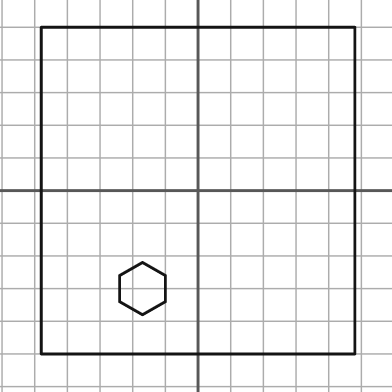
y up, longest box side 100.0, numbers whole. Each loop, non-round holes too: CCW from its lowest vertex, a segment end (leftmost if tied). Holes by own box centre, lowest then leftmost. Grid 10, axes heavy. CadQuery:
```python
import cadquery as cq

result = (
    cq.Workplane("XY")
    .moveTo(-48.0, -50.0)
    .lineTo(48.0, -50.0)
    .lineTo(48.0, 50.0)
    .lineTo(-48.0, 50.0)
    .close()
    .moveTo(-17.0, -38.0)
    .lineTo(-10.0, -34.0)
    .lineTo(-10.0, -26.0)
    .lineTo(-17.0, -22.0)
    .lineTo(-24.0, -26.0)
    .lineTo(-24.0, -34.0)
    .close()
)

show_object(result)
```